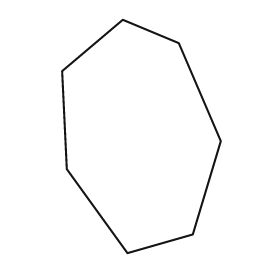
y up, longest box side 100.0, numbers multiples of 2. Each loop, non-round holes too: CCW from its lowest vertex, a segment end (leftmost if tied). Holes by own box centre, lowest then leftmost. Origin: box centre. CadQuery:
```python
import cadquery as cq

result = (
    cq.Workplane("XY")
    .moveTo(-6.0, -50.0)
    .lineTo(22.0, -42.0)
    .lineTo(34.0, -2.0)
    .lineTo(16.0, 40.0)
    .lineTo(-8.0, 50.0)
    .lineTo(-34.0, 28.0)
    .lineTo(-32.0, -14.0)
    .close()
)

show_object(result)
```